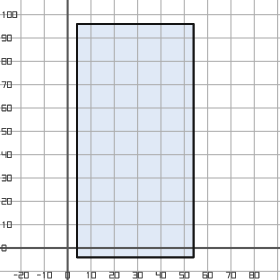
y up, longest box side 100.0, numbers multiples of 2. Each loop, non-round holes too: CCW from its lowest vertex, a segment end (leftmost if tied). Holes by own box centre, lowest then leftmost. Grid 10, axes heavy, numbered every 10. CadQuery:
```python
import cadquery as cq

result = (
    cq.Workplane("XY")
    .moveTo(4.0, -4.0)
    .lineTo(54.0, -4.0)
    .lineTo(54.0, 96.0)
    .lineTo(4.0, 96.0)
    .close()
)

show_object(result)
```